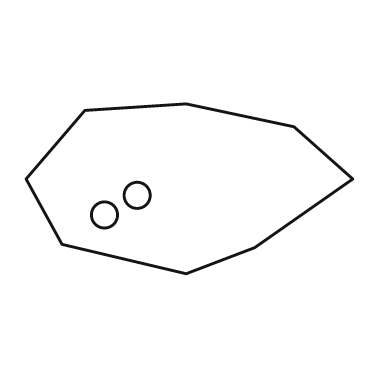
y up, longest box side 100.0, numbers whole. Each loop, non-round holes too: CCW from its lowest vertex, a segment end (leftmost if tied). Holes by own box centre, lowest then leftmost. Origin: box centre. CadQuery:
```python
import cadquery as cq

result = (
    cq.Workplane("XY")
    .moveTo(-1.0, -26.0)
    .lineTo(20.0, -18.0)
    .lineTo(50.0, 3.0)
    .lineTo(32.0, 19.0)
    .lineTo(-1.0, 26.0)
    .lineTo(-32.0, 24.0)
    .lineTo(-50.0, 3.0)
    .lineTo(-39.0, -17.0)
    .close()
    .moveTo(-26.0, -8.0)
    .circle(4.0)
    .moveTo(-16.0, -2.0)
    .circle(4.0)
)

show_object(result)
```